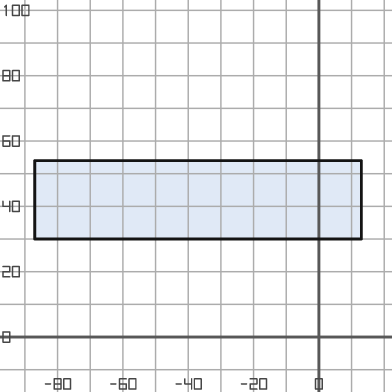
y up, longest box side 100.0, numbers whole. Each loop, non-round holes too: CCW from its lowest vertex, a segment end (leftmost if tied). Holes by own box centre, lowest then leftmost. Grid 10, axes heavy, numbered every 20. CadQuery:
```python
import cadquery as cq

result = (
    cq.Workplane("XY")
    .moveTo(-87.0, 30.0)
    .lineTo(13.0, 30.0)
    .lineTo(13.0, 54.0)
    .lineTo(-87.0, 54.0)
    .close()
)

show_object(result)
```